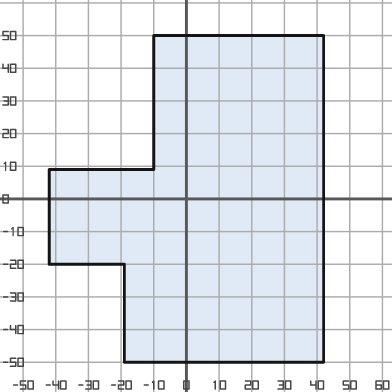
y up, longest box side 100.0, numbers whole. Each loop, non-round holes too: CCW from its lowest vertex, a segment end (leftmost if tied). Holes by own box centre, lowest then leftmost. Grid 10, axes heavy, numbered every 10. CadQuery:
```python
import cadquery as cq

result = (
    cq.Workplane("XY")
    .moveTo(-19.0, -50.0)
    .lineTo(42.0, -50.0)
    .lineTo(42.0, 50.0)
    .lineTo(-10.0, 50.0)
    .lineTo(-10.0, 9.0)
    .lineTo(-42.0, 9.0)
    .lineTo(-42.0, -20.0)
    .lineTo(-19.0, -20.0)
    .close()
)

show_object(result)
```